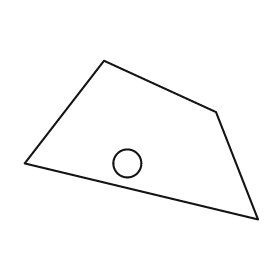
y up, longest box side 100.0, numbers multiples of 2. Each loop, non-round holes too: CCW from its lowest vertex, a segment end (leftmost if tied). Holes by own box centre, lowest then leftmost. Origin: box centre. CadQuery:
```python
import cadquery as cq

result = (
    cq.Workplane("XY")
    .moveTo(50.0, -34.0)
    .lineTo(32.0, 12.0)
    .lineTo(-16.0, 34.0)
    .lineTo(-50.0, -10.0)
    .close()
    .moveTo(-6.0, -10.0)
    .circle(6.0)
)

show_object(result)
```